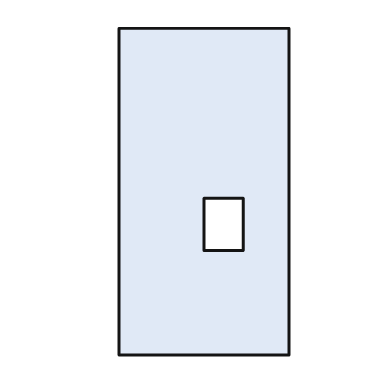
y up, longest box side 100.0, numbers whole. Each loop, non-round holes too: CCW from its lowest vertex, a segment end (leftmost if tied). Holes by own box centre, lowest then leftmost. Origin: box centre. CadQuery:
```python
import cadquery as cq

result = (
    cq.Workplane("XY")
    .moveTo(-26.0, -50.0)
    .lineTo(26.0, -50.0)
    .lineTo(26.0, 50.0)
    .lineTo(-26.0, 50.0)
    .close()
    .moveTo(0.0, -18.0)
    .lineTo(12.0, -18.0)
    .lineTo(12.0, -2.0)
    .lineTo(0.0, -2.0)
    .close()
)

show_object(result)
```